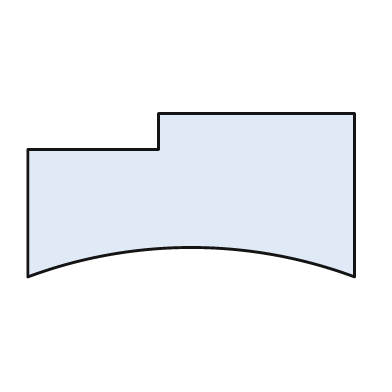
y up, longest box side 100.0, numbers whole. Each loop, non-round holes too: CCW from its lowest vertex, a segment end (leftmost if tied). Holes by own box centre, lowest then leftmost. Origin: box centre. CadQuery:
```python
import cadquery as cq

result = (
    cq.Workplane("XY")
    .moveTo(-50.0, -25.0)
    .threePointArc((0.0, -16.0), (50.0, -25.0))
    .lineTo(50.0, 25.0)
    .lineTo(-10.0, 25.0)
    .lineTo(-10.0, 14.0)
    .lineTo(-50.0, 14.0)
    .close()
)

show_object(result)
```